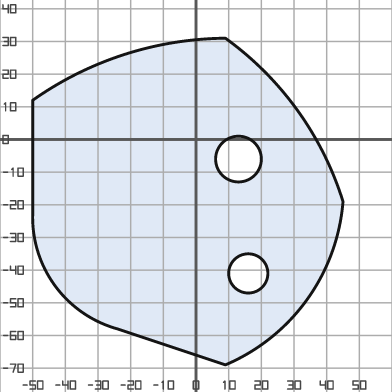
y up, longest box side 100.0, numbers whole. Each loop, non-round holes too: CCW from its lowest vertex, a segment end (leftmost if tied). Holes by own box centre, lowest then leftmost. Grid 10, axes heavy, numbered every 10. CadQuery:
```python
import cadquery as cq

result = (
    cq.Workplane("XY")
    .moveTo(9.0, -69.0)
    .threePointArc((34.0, -49.0), (45.0, -19.0))
    .threePointArc((31.0, 9.0), (9.0, 31.0))
    .threePointArc((-22.0, 26.0), (-50.0, 12.0))
    .lineTo(-50.0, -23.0)
    .threePointArc((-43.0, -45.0), (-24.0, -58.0))
    .close()
    .moveTo(16.0, -41.0)
    .circle(6.0)
    .moveTo(13.0, -6.0)
    .circle(7.0)
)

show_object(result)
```